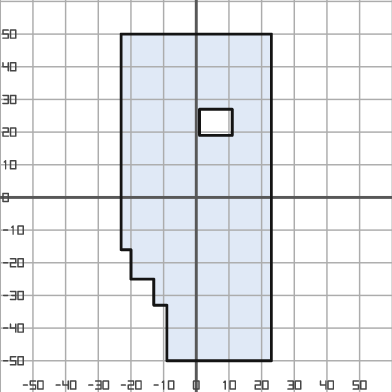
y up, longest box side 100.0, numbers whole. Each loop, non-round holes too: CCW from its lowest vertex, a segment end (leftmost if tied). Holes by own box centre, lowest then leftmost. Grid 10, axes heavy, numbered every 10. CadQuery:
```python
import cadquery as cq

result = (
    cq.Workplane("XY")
    .moveTo(-9.0, -50.0)
    .lineTo(23.0, -50.0)
    .lineTo(23.0, 50.0)
    .lineTo(-23.0, 50.0)
    .lineTo(-23.0, -16.0)
    .lineTo(-20.0, -16.0)
    .lineTo(-20.0, -25.0)
    .lineTo(-13.0, -25.0)
    .lineTo(-13.0, -33.0)
    .lineTo(-9.0, -33.0)
    .close()
    .moveTo(1.0, 19.0)
    .lineTo(11.0, 19.0)
    .lineTo(11.0, 27.0)
    .lineTo(1.0, 27.0)
    .close()
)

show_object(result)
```